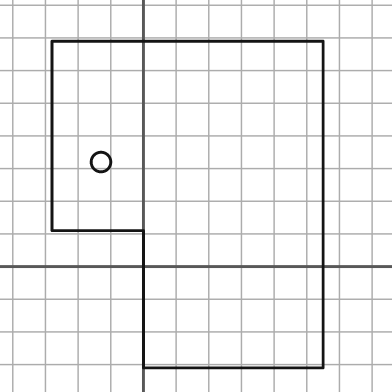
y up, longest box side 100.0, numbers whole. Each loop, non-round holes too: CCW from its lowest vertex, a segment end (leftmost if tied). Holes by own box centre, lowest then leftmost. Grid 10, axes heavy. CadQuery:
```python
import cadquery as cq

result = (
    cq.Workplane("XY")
    .moveTo(0.0, -31.0)
    .lineTo(55.0, -31.0)
    .lineTo(55.0, 69.0)
    .lineTo(-28.0, 69.0)
    .lineTo(-28.0, 11.0)
    .lineTo(0.0, 11.0)
    .close()
    .moveTo(-13.0, 32.0)
    .circle(3.0)
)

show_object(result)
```